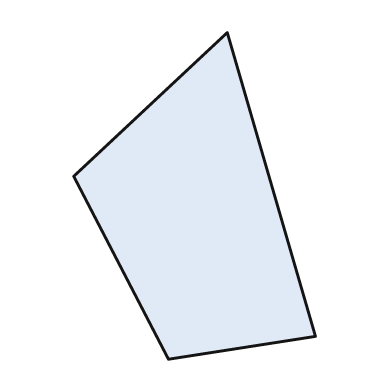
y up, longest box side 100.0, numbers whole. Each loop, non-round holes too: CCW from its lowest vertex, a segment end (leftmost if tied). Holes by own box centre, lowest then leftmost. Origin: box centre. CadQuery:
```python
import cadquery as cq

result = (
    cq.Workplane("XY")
    .moveTo(-8.0, -50.0)
    .lineTo(37.0, -43.0)
    .lineTo(10.0, 50.0)
    .lineTo(-37.0, 6.0)
    .close()
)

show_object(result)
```